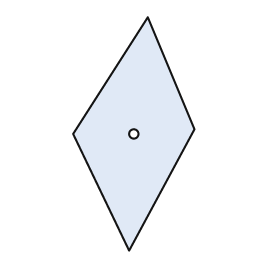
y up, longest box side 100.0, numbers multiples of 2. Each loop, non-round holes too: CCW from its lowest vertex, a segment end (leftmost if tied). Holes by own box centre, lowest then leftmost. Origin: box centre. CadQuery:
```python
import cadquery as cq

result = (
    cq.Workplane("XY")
    .moveTo(-2.0, -50.0)
    .lineTo(26.0, 2.0)
    .lineTo(6.0, 50.0)
    .lineTo(-26.0, 0.0)
    .close()
    .moveTo(0.0, 0.0)
    .circle(2.0)
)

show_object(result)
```